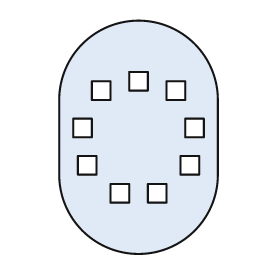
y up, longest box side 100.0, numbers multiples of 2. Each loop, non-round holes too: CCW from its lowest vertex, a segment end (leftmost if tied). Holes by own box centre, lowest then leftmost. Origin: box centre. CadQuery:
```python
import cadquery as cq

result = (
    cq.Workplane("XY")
    .moveTo(-34.0, -16.0)
    .threePointArc((0.0, -50.0), (34.0, -16.0))
    .lineTo(34.0, 16.0)
    .threePointArc((0.0, 50.0), (-34.0, 16.0))
    .close()
    .moveTo(-12.0, -28.0)
    .lineTo(-4.0, -28.0)
    .lineTo(-4.0, -20.0)
    .lineTo(-12.0, -20.0)
    .close()
    .moveTo(4.0, -28.0)
    .lineTo(12.0, -28.0)
    .lineTo(12.0, -20.0)
    .lineTo(4.0, -20.0)
    .close()
    .moveTo(-26.0, -16.0)
    .lineTo(-18.0, -16.0)
    .lineTo(-18.0, -8.0)
    .lineTo(-26.0, -8.0)
    .close()
    .moveTo(18.0, -16.0)
    .lineTo(26.0, -16.0)
    .lineTo(26.0, -8.0)
    .lineTo(18.0, -8.0)
    .close()
    .moveTo(-28.0, 0.0)
    .lineTo(-20.0, 0.0)
    .lineTo(-20.0, 8.0)
    .lineTo(-28.0, 8.0)
    .close()
    .moveTo(20.0, 0.0)
    .lineTo(28.0, 0.0)
    .lineTo(28.0, 8.0)
    .lineTo(20.0, 8.0)
    .close()
    .moveTo(-20.0, 16.0)
    .lineTo(-12.0, 16.0)
    .lineTo(-12.0, 24.0)
    .lineTo(-20.0, 24.0)
    .close()
    .moveTo(12.0, 16.0)
    .lineTo(20.0, 16.0)
    .lineTo(20.0, 24.0)
    .lineTo(12.0, 24.0)
    .close()
    .moveTo(-4.0, 20.0)
    .lineTo(4.0, 20.0)
    .lineTo(4.0, 28.0)
    .lineTo(-4.0, 28.0)
    .close()
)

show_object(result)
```